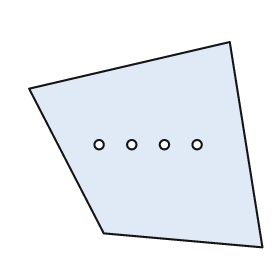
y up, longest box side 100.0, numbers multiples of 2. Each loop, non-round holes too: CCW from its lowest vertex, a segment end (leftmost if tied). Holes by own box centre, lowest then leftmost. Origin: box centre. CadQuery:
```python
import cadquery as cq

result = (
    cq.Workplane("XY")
    .moveTo(50.0, -44.0)
    .lineTo(36.0, 44.0)
    .lineTo(-50.0, 24.0)
    .lineTo(-18.0, -38.0)
    .close()
    .moveTo(-20.0, 0.0)
    .circle(2.0)
    .moveTo(-6.0, 0.0)
    .circle(2.0)
    .moveTo(8.0, 0.0)
    .circle(2.0)
    .moveTo(22.0, 0.0)
    .circle(2.0)
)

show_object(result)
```